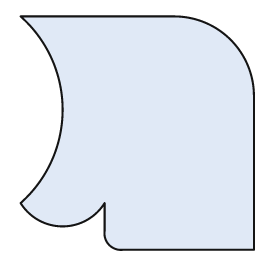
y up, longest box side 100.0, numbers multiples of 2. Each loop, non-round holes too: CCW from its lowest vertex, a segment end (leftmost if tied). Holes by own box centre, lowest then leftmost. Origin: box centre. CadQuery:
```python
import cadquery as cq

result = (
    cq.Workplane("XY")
    .moveTo(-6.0, -50.0)
    .lineTo(50.0, -50.0)
    .lineTo(50.0, 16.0)
    .threePointArc((40.0, 40.0), (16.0, 50.0))
    .lineTo(-50.0, 50.0)
    .threePointArc((-32.0, 10.0), (-50.0, -30.0))
    .threePointArc((-32.0, -40.0), (-14.0, -30.0))
    .lineTo(-14.0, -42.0)
    .threePointArc((-12.0, -48.0), (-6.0, -50.0))
    .close()
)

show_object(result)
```